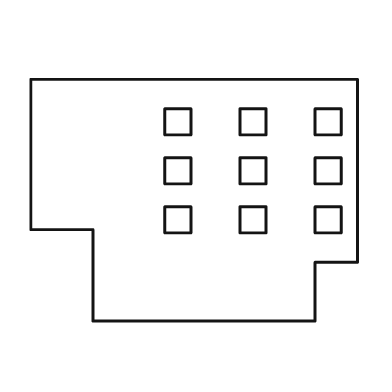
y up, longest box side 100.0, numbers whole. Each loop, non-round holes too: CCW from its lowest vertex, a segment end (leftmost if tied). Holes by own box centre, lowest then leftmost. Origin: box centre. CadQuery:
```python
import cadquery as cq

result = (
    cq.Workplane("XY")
    .moveTo(-31.0, -37.0)
    .lineTo(37.0, -37.0)
    .lineTo(37.0, -19.0)
    .lineTo(50.0, -19.0)
    .lineTo(50.0, 37.0)
    .lineTo(-50.0, 37.0)
    .lineTo(-50.0, -9.0)
    .lineTo(-31.0, -9.0)
    .close()
    .moveTo(-9.0, -10.0)
    .lineTo(-1.0, -10.0)
    .lineTo(-1.0, -2.0)
    .lineTo(-9.0, -2.0)
    .close()
    .moveTo(14.0, -10.0)
    .lineTo(22.0, -10.0)
    .lineTo(22.0, -2.0)
    .lineTo(14.0, -2.0)
    .close()
    .moveTo(37.0, -10.0)
    .lineTo(45.0, -10.0)
    .lineTo(45.0, -2.0)
    .lineTo(37.0, -2.0)
    .close()
    .moveTo(-9.0, 5.0)
    .lineTo(-1.0, 5.0)
    .lineTo(-1.0, 13.0)
    .lineTo(-9.0, 13.0)
    .close()
    .moveTo(14.0, 5.0)
    .lineTo(22.0, 5.0)
    .lineTo(22.0, 13.0)
    .lineTo(14.0, 13.0)
    .close()
    .moveTo(37.0, 5.0)
    .lineTo(45.0, 5.0)
    .lineTo(45.0, 13.0)
    .lineTo(37.0, 13.0)
    .close()
    .moveTo(-9.0, 20.0)
    .lineTo(-1.0, 20.0)
    .lineTo(-1.0, 28.0)
    .lineTo(-9.0, 28.0)
    .close()
    .moveTo(14.0, 20.0)
    .lineTo(22.0, 20.0)
    .lineTo(22.0, 28.0)
    .lineTo(14.0, 28.0)
    .close()
    .moveTo(37.0, 20.0)
    .lineTo(45.0, 20.0)
    .lineTo(45.0, 28.0)
    .lineTo(37.0, 28.0)
    .close()
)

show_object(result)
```